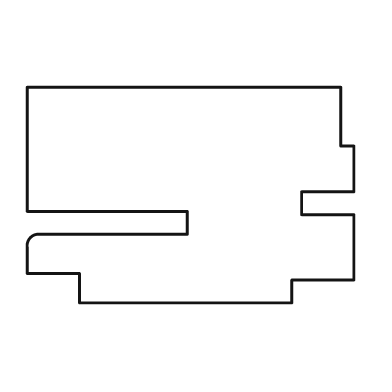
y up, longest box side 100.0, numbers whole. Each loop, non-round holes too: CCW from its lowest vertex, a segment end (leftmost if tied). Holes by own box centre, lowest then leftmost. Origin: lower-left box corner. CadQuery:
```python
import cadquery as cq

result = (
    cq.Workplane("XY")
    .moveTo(16.0, 0.0)
    .lineTo(81.0, 0.0)
    .lineTo(81.0, 7.0)
    .lineTo(100.0, 7.0)
    .lineTo(100.0, 27.0)
    .lineTo(84.0, 27.0)
    .lineTo(84.0, 34.0)
    .lineTo(100.0, 34.0)
    .lineTo(100.0, 48.0)
    .lineTo(96.0, 48.0)
    .lineTo(96.0, 66.0)
    .lineTo(0.0, 66.0)
    .lineTo(0.0, 28.0)
    .lineTo(49.0, 28.0)
    .lineTo(49.0, 21.0)
    .lineTo(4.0, 21.0)
    .threePointArc((1.0, 20.0), (0.0, 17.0))
    .lineTo(0.0, 9.0)
    .lineTo(16.0, 9.0)
    .close()
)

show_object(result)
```